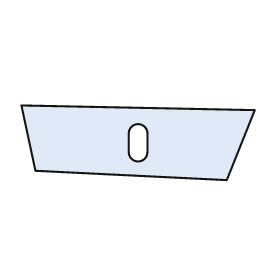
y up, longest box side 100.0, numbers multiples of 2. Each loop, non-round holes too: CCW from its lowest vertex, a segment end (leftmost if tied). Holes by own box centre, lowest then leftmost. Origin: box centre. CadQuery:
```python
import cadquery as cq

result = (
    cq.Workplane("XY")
    .moveTo(38.0, -16.0)
    .lineTo(50.0, 14.0)
    .lineTo(-50.0, 16.0)
    .lineTo(-44.0, -12.0)
    .close()
    .moveTo(-4.0, -4.0)
    .threePointArc((0.0, -8.0), (4.0, -4.0))
    .lineTo(4.0, 4.0)
    .threePointArc((0.0, 8.0), (-4.0, 4.0))
    .close()
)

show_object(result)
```